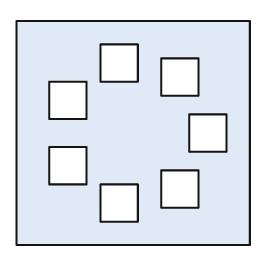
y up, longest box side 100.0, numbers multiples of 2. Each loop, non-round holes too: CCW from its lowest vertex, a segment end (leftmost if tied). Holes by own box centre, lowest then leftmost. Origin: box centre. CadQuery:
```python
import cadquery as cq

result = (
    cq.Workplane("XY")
    .moveTo(-50.0, -48.0)
    .lineTo(50.0, -48.0)
    .lineTo(50.0, 48.0)
    .lineTo(-50.0, 48.0)
    .close()
    .moveTo(-14.0, -38.0)
    .lineTo(2.0, -38.0)
    .lineTo(2.0, -22.0)
    .lineTo(-14.0, -22.0)
    .close()
    .moveTo(12.0, -32.0)
    .lineTo(28.0, -32.0)
    .lineTo(28.0, -16.0)
    .lineTo(12.0, -16.0)
    .close()
    .moveTo(-36.0, -22.0)
    .lineTo(-20.0, -22.0)
    .lineTo(-20.0, -6.0)
    .lineTo(-36.0, -6.0)
    .close()
    .moveTo(24.0, -8.0)
    .lineTo(40.0, -8.0)
    .lineTo(40.0, 8.0)
    .lineTo(24.0, 8.0)
    .close()
    .moveTo(-36.0, 6.0)
    .lineTo(-20.0, 6.0)
    .lineTo(-20.0, 22.0)
    .lineTo(-36.0, 22.0)
    .close()
    .moveTo(12.0, 16.0)
    .lineTo(28.0, 16.0)
    .lineTo(28.0, 32.0)
    .lineTo(12.0, 32.0)
    .close()
    .moveTo(-14.0, 22.0)
    .lineTo(2.0, 22.0)
    .lineTo(2.0, 38.0)
    .lineTo(-14.0, 38.0)
    .close()
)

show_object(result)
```